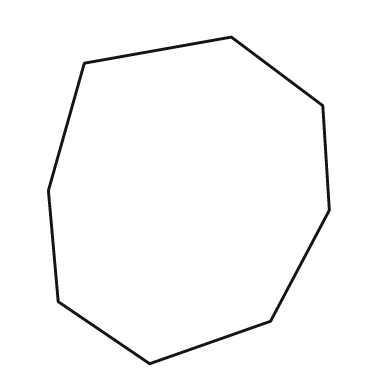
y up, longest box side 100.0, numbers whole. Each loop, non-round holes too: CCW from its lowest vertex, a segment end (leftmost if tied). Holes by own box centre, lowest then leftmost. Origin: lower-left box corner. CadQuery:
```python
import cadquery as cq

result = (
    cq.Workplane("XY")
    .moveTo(31.0, 0.0)
    .lineTo(68.0, 13.0)
    .lineTo(86.0, 47.0)
    .lineTo(84.0, 79.0)
    .lineTo(56.0, 100.0)
    .lineTo(11.0, 92.0)
    .lineTo(0.0, 53.0)
    .lineTo(3.0, 19.0)
    .close()
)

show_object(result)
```